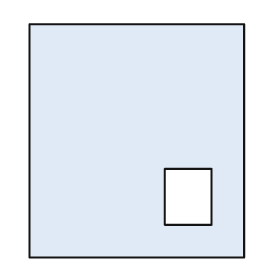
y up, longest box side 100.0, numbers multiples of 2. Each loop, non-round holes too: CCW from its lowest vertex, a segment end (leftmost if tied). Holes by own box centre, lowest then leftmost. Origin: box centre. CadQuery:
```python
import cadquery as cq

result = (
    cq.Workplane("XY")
    .moveTo(-46.0, -50.0)
    .lineTo(46.0, -50.0)
    .lineTo(46.0, 50.0)
    .lineTo(-46.0, 50.0)
    .close()
    .moveTo(12.0, -36.0)
    .lineTo(32.0, -36.0)
    .lineTo(32.0, -12.0)
    .lineTo(12.0, -12.0)
    .close()
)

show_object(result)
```